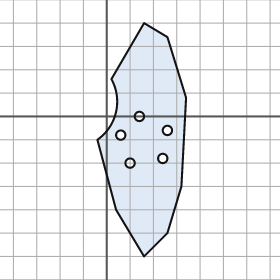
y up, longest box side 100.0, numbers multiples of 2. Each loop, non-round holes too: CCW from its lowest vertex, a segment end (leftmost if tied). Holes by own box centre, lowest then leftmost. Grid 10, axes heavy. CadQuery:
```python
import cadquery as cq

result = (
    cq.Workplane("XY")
    .moveTo(16.0, -60.0)
    .lineTo(26.0, -50.0)
    .lineTo(32.0, -30.0)
    .lineTo(34.0, 8.0)
    .lineTo(26.0, 34.0)
    .lineTo(16.0, 40.0)
    .lineTo(2.0, 16.0)
    .threePointArc((4.0, 2.0), (-4.0, -10.0))
    .lineTo(4.0, -40.0)
    .close()
    .moveTo(10.0, -20.0)
    .circle(2.0)
    .moveTo(24.0, -18.0)
    .circle(2.0)
    .moveTo(6.0, -8.0)
    .circle(2.0)
    .moveTo(26.0, -6.0)
    .circle(2.0)
    .moveTo(14.0, 0.0)
    .circle(2.0)
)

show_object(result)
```